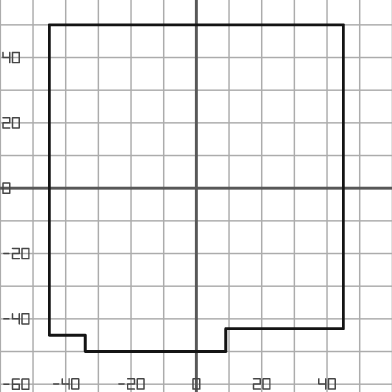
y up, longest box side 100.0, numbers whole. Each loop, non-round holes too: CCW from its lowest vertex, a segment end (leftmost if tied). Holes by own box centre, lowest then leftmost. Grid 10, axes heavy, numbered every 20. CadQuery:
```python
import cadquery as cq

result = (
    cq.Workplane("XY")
    .moveTo(-34.0, -50.0)
    .lineTo(9.0, -50.0)
    .lineTo(9.0, -43.0)
    .lineTo(45.0, -43.0)
    .lineTo(45.0, 50.0)
    .lineTo(-45.0, 50.0)
    .lineTo(-45.0, -45.0)
    .lineTo(-34.0, -45.0)
    .close()
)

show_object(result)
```